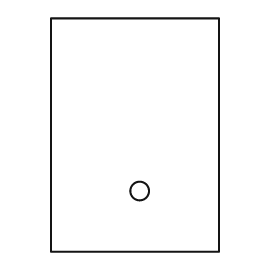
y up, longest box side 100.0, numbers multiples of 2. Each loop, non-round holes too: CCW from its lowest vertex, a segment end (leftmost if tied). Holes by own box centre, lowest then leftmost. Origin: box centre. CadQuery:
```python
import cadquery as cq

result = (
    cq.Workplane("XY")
    .moveTo(-36.0, -50.0)
    .lineTo(36.0, -50.0)
    .lineTo(36.0, 50.0)
    .lineTo(-36.0, 50.0)
    .close()
    .moveTo(2.0, -24.0)
    .circle(4.0)
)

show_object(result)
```